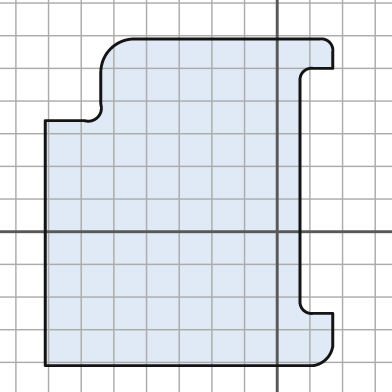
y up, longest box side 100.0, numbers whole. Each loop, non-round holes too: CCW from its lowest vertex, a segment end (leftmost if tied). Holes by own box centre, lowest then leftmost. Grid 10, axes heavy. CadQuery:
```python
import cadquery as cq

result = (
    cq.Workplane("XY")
    .moveTo(-71.0, -41.0)
    .lineTo(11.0, -41.0)
    .threePointArc((15.0, -39.0), (17.0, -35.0))
    .lineTo(17.0, -25.0)
    .lineTo(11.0, -25.0)
    .threePointArc((8.0, -24.0), (7.0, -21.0))
    .lineTo(7.0, 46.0)
    .threePointArc((8.0, 49.0), (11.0, 50.0))
    .lineTo(17.0, 50.0)
    .lineTo(17.0, 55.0)
    .threePointArc((16.0, 58.0), (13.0, 59.0))
    .lineTo(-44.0, 59.0)
    .threePointArc((-51.0, 56.0), (-54.0, 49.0))
    .lineTo(-54.0, 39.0)
    .threePointArc((-55.0, 35.0), (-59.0, 34.0))
    .lineTo(-71.0, 34.0)
    .close()
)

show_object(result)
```